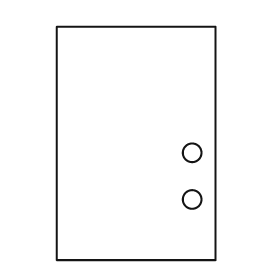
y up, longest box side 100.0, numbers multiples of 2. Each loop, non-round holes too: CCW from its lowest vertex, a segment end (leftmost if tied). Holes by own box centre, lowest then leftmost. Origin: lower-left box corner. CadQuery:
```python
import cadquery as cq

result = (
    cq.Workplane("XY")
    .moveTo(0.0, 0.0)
    .lineTo(68.0, 0.0)
    .lineTo(68.0, 100.0)
    .lineTo(0.0, 100.0)
    .close()
    .moveTo(58.0, 26.0)
    .circle(4.0)
    .moveTo(58.0, 46.0)
    .circle(4.0)
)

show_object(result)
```